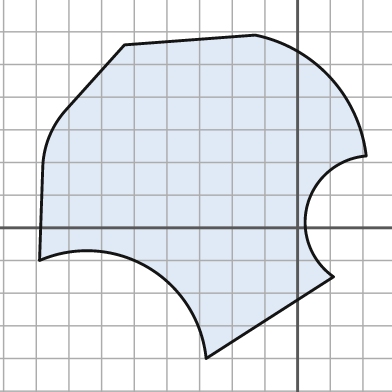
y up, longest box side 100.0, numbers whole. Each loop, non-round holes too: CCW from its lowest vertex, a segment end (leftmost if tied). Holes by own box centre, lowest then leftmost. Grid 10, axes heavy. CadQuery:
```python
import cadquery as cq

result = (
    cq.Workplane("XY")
    .moveTo(-28.0, -40.0)
    .lineTo(11.0, -15.0)
    .threePointArc((3.0, 7.0), (21.0, 22.0))
    .threePointArc((10.0, 46.0), (-13.0, 59.0))
    .lineTo(-53.0, 56.0)
    .lineTo(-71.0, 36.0)
    .threePointArc((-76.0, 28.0), (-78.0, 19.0))
    .lineTo(-79.0, -10.0)
    .threePointArc((-46.0, -12.0), (-28.0, -40.0))
    .close()
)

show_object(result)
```